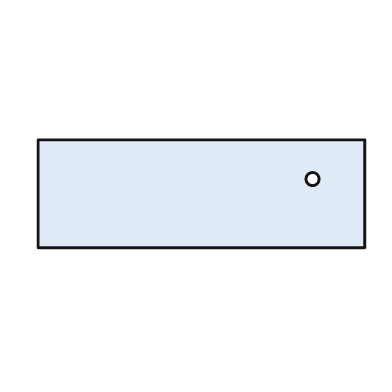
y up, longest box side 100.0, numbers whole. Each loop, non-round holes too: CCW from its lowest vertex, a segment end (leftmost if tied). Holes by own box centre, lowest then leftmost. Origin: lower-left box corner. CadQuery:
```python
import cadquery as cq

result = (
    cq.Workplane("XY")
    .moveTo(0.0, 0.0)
    .lineTo(100.0, 0.0)
    .lineTo(100.0, 33.0)
    .lineTo(0.0, 33.0)
    .close()
    .moveTo(84.0, 21.0)
    .circle(2.0)
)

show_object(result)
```